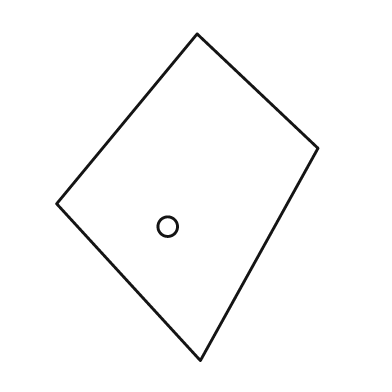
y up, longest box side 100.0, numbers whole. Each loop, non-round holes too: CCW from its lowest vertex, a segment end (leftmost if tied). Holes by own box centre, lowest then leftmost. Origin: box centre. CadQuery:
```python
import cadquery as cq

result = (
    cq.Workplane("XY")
    .moveTo(4.0, -50.0)
    .lineTo(40.0, 15.0)
    .lineTo(3.0, 50.0)
    .lineTo(-40.0, -2.0)
    .close()
    .moveTo(-6.0, -9.0)
    .circle(3.0)
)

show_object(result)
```